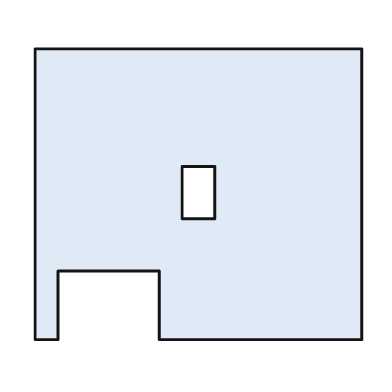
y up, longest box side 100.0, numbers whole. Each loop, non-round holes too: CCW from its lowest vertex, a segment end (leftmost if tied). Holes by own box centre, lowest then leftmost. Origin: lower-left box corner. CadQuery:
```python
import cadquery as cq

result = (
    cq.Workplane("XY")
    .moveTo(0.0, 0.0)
    .lineTo(7.0, 0.0)
    .lineTo(7.0, 21.0)
    .lineTo(38.0, 21.0)
    .lineTo(38.0, 0.0)
    .lineTo(100.0, 0.0)
    .lineTo(100.0, 89.0)
    .lineTo(0.0, 89.0)
    .close()
    .moveTo(45.0, 37.0)
    .lineTo(55.0, 37.0)
    .lineTo(55.0, 53.0)
    .lineTo(45.0, 53.0)
    .close()
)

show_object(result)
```